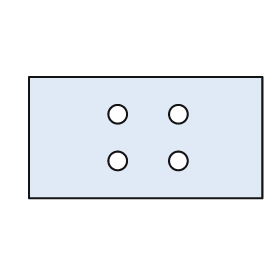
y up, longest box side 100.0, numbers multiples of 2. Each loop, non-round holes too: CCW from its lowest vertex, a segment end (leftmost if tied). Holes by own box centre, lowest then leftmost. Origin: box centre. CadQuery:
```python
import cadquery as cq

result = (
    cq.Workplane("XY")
    .moveTo(-50.0, -26.0)
    .lineTo(50.0, -26.0)
    .lineTo(50.0, 26.0)
    .lineTo(-50.0, 26.0)
    .close()
    .moveTo(-12.0, -10.0)
    .circle(4.0)
    .moveTo(14.0, -10.0)
    .circle(4.0)
    .moveTo(-12.0, 10.0)
    .circle(4.0)
    .moveTo(14.0, 10.0)
    .circle(4.0)
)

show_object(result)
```